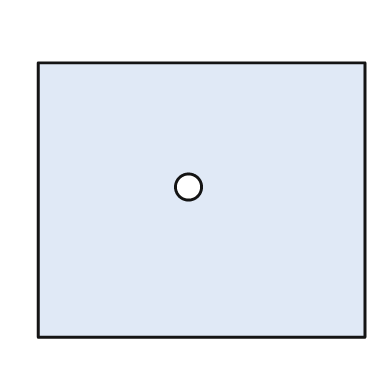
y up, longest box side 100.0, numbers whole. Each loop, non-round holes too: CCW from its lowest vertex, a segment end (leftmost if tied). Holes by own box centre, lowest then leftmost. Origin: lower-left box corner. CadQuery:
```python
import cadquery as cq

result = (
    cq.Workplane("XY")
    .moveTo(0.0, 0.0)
    .lineTo(100.0, 0.0)
    .lineTo(100.0, 84.0)
    .lineTo(0.0, 84.0)
    .close()
    .moveTo(46.0, 46.0)
    .circle(4.0)
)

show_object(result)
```